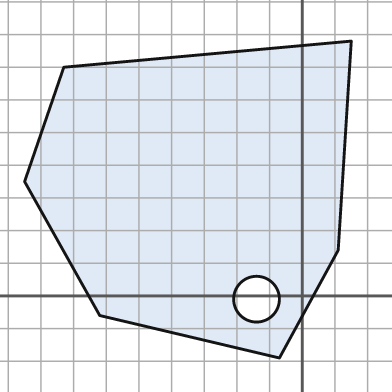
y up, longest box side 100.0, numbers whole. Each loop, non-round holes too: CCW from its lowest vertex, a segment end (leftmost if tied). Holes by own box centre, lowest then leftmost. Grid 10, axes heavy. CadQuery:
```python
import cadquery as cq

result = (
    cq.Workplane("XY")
    .moveTo(-7.0, -19.0)
    .lineTo(11.0, 14.0)
    .lineTo(15.0, 78.0)
    .lineTo(-73.0, 70.0)
    .lineTo(-85.0, 35.0)
    .lineTo(-62.0, -6.0)
    .close()
    .moveTo(-14.0, -1.0)
    .circle(7.0)
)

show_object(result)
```